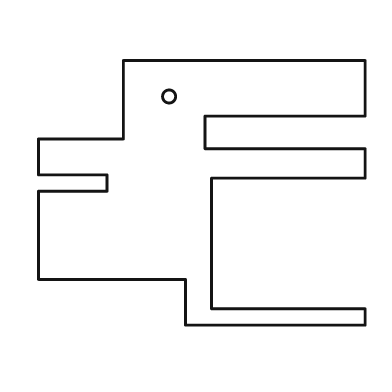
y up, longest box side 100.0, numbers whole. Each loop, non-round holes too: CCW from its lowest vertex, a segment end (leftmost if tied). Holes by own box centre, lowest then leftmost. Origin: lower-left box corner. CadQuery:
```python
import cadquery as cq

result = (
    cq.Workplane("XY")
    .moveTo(45.0, 0.0)
    .lineTo(100.0, 0.0)
    .lineTo(100.0, 5.0)
    .lineTo(53.0, 5.0)
    .lineTo(53.0, 45.0)
    .lineTo(100.0, 45.0)
    .lineTo(100.0, 54.0)
    .lineTo(51.0, 54.0)
    .lineTo(51.0, 64.0)
    .lineTo(100.0, 64.0)
    .lineTo(100.0, 81.0)
    .lineTo(26.0, 81.0)
    .lineTo(26.0, 57.0)
    .lineTo(0.0, 57.0)
    .lineTo(0.0, 46.0)
    .lineTo(21.0, 46.0)
    .lineTo(21.0, 41.0)
    .lineTo(0.0, 41.0)
    .lineTo(0.0, 14.0)
    .lineTo(45.0, 14.0)
    .close()
    .moveTo(40.0, 70.0)
    .circle(2.0)
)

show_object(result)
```